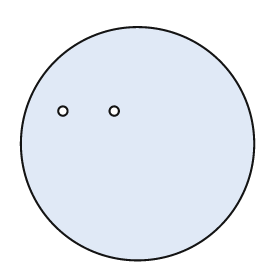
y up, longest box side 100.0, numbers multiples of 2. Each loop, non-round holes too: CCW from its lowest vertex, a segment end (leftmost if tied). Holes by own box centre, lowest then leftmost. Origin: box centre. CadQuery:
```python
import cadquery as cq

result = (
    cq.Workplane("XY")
    .moveTo(0.0, 0.0)
    .circle(50.0)
    .moveTo(-32.0, 14.0)
    .circle(2.0)
    .moveTo(-10.0, 14.0)
    .circle(2.0)
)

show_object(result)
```